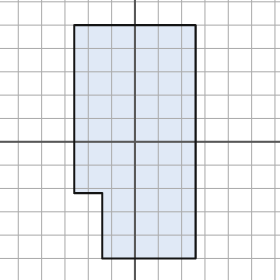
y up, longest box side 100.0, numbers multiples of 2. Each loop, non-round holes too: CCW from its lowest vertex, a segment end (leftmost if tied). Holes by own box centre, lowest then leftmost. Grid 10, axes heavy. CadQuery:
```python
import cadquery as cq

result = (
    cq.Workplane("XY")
    .moveTo(-14.0, -50.0)
    .lineTo(26.0, -50.0)
    .lineTo(26.0, 50.0)
    .lineTo(-26.0, 50.0)
    .lineTo(-26.0, -22.0)
    .lineTo(-14.0, -22.0)
    .close()
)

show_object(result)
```